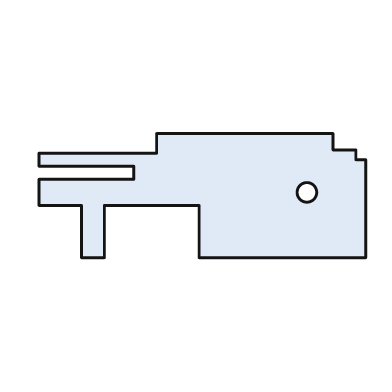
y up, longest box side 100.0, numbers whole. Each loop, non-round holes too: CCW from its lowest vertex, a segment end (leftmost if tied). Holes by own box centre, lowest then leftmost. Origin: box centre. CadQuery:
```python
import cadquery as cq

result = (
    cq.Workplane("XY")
    .moveTo(-37.0, -19.0)
    .lineTo(-30.0, -19.0)
    .lineTo(-30.0, -3.0)
    .lineTo(-1.0, -3.0)
    .lineTo(-1.0, -19.0)
    .lineTo(50.0, -19.0)
    .lineTo(50.0, 11.0)
    .lineTo(47.0, 11.0)
    .lineTo(47.0, 14.0)
    .lineTo(40.0, 14.0)
    .lineTo(40.0, 19.0)
    .lineTo(-14.0, 19.0)
    .lineTo(-14.0, 13.0)
    .lineTo(-50.0, 13.0)
    .lineTo(-50.0, 9.0)
    .lineTo(-21.0, 9.0)
    .lineTo(-21.0, 5.0)
    .lineTo(-50.0, 5.0)
    .lineTo(-50.0, -3.0)
    .lineTo(-37.0, -3.0)
    .close()
    .moveTo(32.0, 1.0)
    .circle(3.0)
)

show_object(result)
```